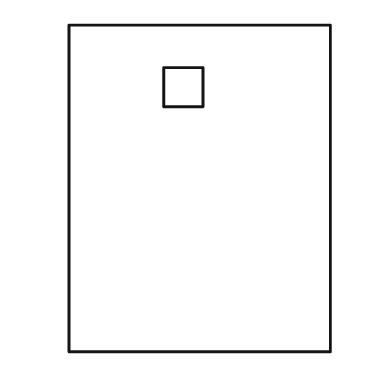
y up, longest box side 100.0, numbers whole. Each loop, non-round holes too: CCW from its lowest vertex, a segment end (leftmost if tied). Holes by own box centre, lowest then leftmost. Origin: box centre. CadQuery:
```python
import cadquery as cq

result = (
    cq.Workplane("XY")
    .moveTo(-40.0, -50.0)
    .lineTo(40.0, -50.0)
    .lineTo(40.0, 50.0)
    .lineTo(-40.0, 50.0)
    .close()
    .moveTo(-11.0, 25.0)
    .lineTo(1.0, 25.0)
    .lineTo(1.0, 37.0)
    .lineTo(-11.0, 37.0)
    .close()
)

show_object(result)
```